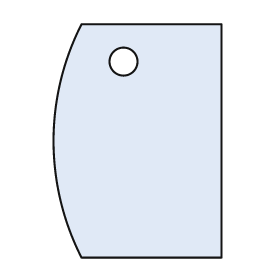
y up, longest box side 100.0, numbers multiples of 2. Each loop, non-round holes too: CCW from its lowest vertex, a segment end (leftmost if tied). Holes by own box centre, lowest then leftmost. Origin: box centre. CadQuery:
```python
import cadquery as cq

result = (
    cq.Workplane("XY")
    .moveTo(-24.0, -50.0)
    .lineTo(36.0, -50.0)
    .lineTo(36.0, 50.0)
    .lineTo(-24.0, 50.0)
    .threePointArc((-36.0, 0.0), (-24.0, -50.0))
    .close()
    .moveTo(-6.0, 34.0)
    .circle(6.0)
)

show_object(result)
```